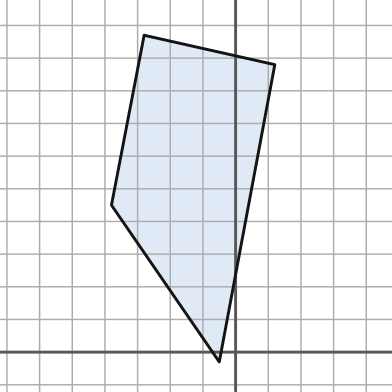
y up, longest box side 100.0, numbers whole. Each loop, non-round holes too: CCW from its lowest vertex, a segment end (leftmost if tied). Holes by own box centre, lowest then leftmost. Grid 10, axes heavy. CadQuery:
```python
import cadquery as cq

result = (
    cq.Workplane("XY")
    .moveTo(-5.0, -3.0)
    .lineTo(12.0, 88.0)
    .lineTo(-28.0, 97.0)
    .lineTo(-38.0, 45.0)
    .close()
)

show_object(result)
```